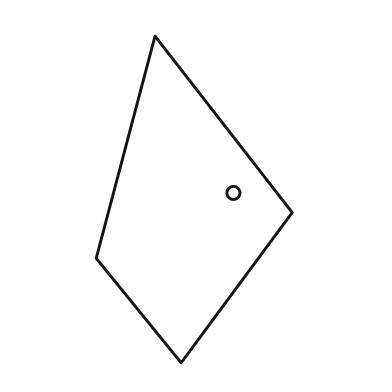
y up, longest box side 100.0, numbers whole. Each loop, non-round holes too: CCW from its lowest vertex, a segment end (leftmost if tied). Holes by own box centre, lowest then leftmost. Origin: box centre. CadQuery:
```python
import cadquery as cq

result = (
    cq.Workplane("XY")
    .moveTo(-4.0, -50.0)
    .lineTo(30.0, -4.0)
    .lineTo(-12.0, 50.0)
    .lineTo(-30.0, -18.0)
    .close()
    .moveTo(12.0, 2.0)
    .circle(2.0)
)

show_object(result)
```